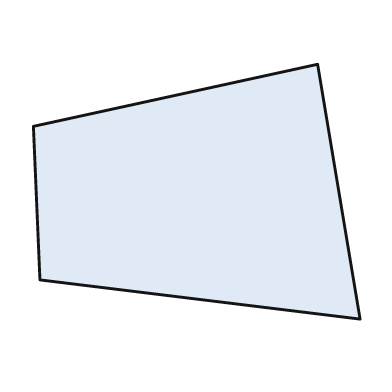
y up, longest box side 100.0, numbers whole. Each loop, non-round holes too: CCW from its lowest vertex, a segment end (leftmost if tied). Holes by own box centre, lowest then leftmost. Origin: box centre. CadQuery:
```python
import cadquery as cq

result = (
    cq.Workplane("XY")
    .moveTo(50.0, -39.0)
    .lineTo(37.0, 39.0)
    .lineTo(-50.0, 20.0)
    .lineTo(-48.0, -27.0)
    .close()
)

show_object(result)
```